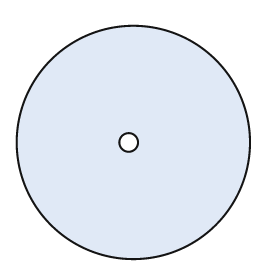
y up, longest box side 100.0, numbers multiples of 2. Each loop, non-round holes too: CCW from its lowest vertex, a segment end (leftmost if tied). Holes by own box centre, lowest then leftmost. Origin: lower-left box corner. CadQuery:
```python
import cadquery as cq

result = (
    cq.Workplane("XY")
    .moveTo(50.0, 50.0)
    .circle(50.0)
    .moveTo(48.0, 50.0)
    .circle(4.0)
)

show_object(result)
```